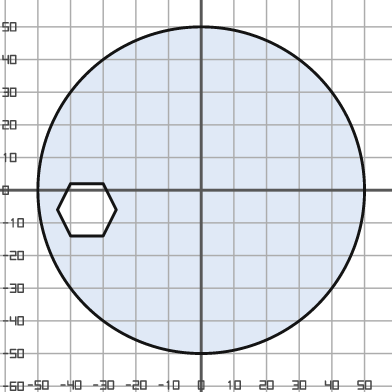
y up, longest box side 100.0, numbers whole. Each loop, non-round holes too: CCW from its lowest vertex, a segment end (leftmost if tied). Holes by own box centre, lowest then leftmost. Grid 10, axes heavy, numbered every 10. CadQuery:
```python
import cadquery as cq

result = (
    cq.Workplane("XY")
    .moveTo(0.0, 0.0)
    .circle(50.0)
    .moveTo(-40.0, -14.0)
    .lineTo(-30.0, -14.0)
    .lineTo(-26.0, -6.0)
    .lineTo(-30.0, 2.0)
    .lineTo(-40.0, 2.0)
    .lineTo(-44.0, -6.0)
    .close()
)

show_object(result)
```